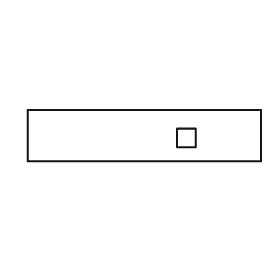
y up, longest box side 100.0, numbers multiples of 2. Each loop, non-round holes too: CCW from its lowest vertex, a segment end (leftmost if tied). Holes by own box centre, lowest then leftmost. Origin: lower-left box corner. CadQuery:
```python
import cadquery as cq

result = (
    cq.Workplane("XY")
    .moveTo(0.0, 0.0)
    .lineTo(100.0, 0.0)
    .lineTo(100.0, 22.0)
    .lineTo(0.0, 22.0)
    .close()
    .moveTo(64.0, 6.0)
    .lineTo(72.0, 6.0)
    .lineTo(72.0, 14.0)
    .lineTo(64.0, 14.0)
    .close()
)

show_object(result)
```